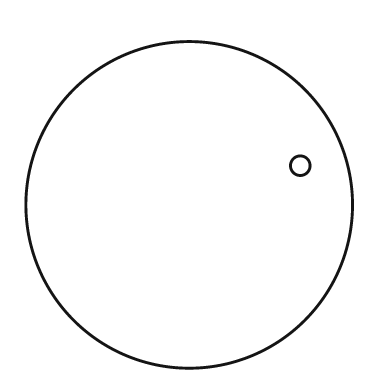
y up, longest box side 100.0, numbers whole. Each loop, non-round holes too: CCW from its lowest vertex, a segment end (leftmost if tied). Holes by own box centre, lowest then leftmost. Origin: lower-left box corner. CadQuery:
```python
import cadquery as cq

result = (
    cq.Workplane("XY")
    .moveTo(50.0, 50.0)
    .circle(50.0)
    .moveTo(84.0, 62.0)
    .circle(3.0)
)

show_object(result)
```